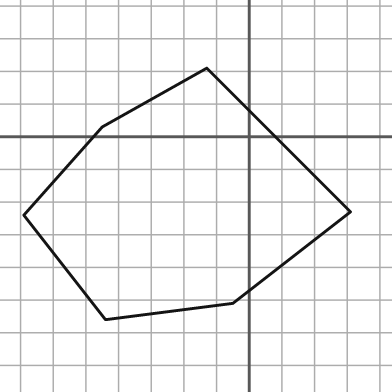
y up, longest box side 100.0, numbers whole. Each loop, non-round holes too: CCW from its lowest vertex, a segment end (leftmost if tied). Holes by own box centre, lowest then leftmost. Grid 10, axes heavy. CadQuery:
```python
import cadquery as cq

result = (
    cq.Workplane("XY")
    .moveTo(-44.0, -56.0)
    .lineTo(-5.0, -51.0)
    .lineTo(31.0, -23.0)
    .lineTo(-13.0, 21.0)
    .lineTo(-45.0, 3.0)
    .lineTo(-69.0, -24.0)
    .close()
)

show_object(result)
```